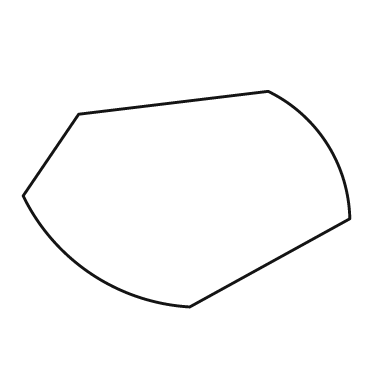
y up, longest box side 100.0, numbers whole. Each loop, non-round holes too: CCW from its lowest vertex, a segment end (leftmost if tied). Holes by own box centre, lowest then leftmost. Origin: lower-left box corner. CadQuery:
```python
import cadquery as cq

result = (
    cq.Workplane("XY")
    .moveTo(51.0, 0.0)
    .lineTo(100.0, 27.0)
    .threePointArc((93.0, 50.0), (75.0, 66.0))
    .lineTo(17.0, 59.0)
    .lineTo(0.0, 34.0)
    .threePointArc((21.0, 10.0), (51.0, 0.0))
    .close()
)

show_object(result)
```